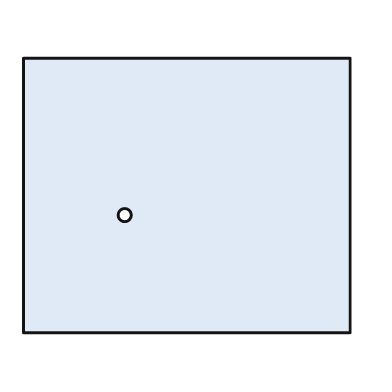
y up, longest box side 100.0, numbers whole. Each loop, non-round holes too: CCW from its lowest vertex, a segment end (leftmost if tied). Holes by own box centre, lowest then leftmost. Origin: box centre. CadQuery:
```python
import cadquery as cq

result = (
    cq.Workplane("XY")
    .moveTo(-50.0, -42.0)
    .lineTo(50.0, -42.0)
    .lineTo(50.0, 42.0)
    .lineTo(-50.0, 42.0)
    .close()
    .moveTo(-19.0, -6.0)
    .circle(2.0)
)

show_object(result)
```